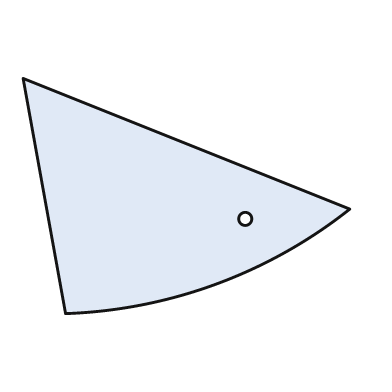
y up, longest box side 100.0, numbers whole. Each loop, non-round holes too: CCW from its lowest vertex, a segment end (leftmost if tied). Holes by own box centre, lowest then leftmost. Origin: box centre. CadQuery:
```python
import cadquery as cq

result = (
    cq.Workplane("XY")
    .moveTo(-37.0, -36.0)
    .threePointArc((9.0, -27.0), (50.0, -4.0))
    .lineTo(-50.0, 36.0)
    .close()
    .moveTo(18.0, -7.0)
    .circle(2.0)
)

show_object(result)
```